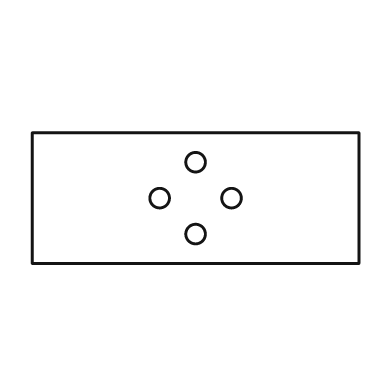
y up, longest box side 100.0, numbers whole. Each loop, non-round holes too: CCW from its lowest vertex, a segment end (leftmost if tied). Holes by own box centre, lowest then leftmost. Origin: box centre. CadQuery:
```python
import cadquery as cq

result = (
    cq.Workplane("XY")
    .moveTo(-50.0, -20.0)
    .lineTo(50.0, -20.0)
    .lineTo(50.0, 20.0)
    .lineTo(-50.0, 20.0)
    .close()
    .moveTo(0.0, -11.0)
    .circle(3.0)
    .moveTo(-11.0, 0.0)
    .circle(3.0)
    .moveTo(11.0, 0.0)
    .circle(3.0)
    .moveTo(0.0, 11.0)
    .circle(3.0)
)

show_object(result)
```